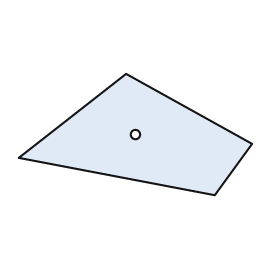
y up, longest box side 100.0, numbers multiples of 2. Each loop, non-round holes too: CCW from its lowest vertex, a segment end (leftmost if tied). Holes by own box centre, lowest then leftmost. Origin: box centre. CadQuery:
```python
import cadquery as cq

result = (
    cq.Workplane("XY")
    .moveTo(34.0, -26.0)
    .lineTo(50.0, -4.0)
    .lineTo(-4.0, 26.0)
    .lineTo(-50.0, -10.0)
    .close()
    .moveTo(0.0, 0.0)
    .circle(2.0)
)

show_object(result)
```